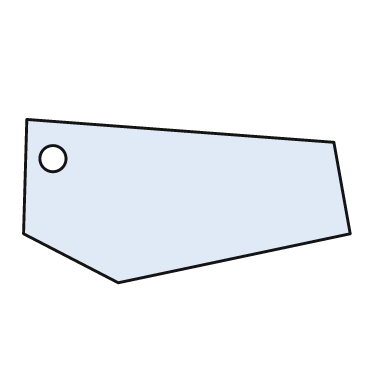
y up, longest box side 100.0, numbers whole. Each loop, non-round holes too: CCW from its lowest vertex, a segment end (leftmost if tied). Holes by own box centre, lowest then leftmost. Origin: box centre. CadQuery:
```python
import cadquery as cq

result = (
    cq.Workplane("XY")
    .moveTo(-21.0, -25.0)
    .lineTo(50.0, -10.0)
    .lineTo(45.0, 18.0)
    .lineTo(-49.0, 25.0)
    .lineTo(-50.0, -10.0)
    .close()
    .moveTo(-41.0, 13.0)
    .circle(4.0)
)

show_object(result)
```